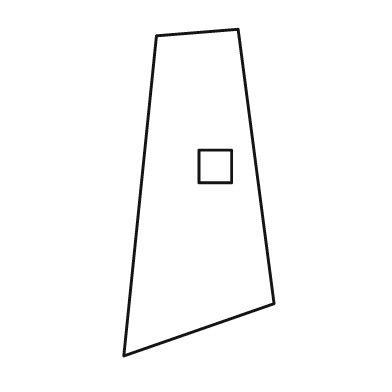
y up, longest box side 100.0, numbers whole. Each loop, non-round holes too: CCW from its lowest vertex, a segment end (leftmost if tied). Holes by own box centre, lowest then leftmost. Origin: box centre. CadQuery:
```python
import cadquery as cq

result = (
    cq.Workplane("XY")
    .moveTo(-23.0, -50.0)
    .lineTo(23.0, -34.0)
    .lineTo(12.0, 50.0)
    .lineTo(-13.0, 48.0)
    .close()
    .moveTo(0.0, 3.0)
    .lineTo(10.0, 3.0)
    .lineTo(10.0, 13.0)
    .lineTo(0.0, 13.0)
    .close()
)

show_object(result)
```